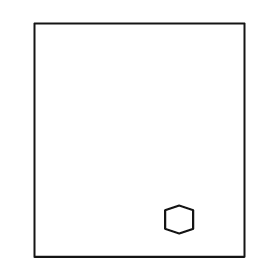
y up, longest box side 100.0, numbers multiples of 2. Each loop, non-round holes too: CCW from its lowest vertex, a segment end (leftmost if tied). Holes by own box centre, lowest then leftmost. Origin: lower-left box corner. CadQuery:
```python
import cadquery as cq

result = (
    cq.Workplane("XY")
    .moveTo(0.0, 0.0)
    .lineTo(90.0, 0.0)
    .lineTo(90.0, 100.0)
    .lineTo(0.0, 100.0)
    .close()
    .moveTo(62.0, 10.0)
    .lineTo(68.0, 12.0)
    .lineTo(68.0, 20.0)
    .lineTo(62.0, 22.0)
    .lineTo(56.0, 20.0)
    .lineTo(56.0, 12.0)
    .close()
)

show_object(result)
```